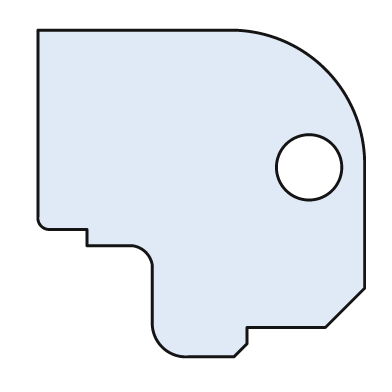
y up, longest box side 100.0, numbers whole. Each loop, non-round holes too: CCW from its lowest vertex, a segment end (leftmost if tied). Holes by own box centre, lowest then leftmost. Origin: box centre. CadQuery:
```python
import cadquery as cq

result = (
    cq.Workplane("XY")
    .moveTo(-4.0, -50.0)
    .lineTo(10.0, -50.0)
    .lineTo(14.0, -46.0)
    .lineTo(14.0, -41.0)
    .lineTo(38.0, -41.0)
    .lineTo(50.0, -29.0)
    .lineTo(50.0, 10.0)
    .threePointArc((38.0, 38.0), (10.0, 50.0))
    .lineTo(-50.0, 50.0)
    .lineTo(-50.0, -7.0)
    .threePointArc((-49.0, -10.0), (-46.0, -11.0))
    .lineTo(-35.0, -11.0)
    .lineTo(-35.0, -16.0)
    .lineTo(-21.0, -16.0)
    .threePointArc((-17.0, -18.0), (-15.0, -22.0))
    .lineTo(-15.0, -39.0)
    .threePointArc((-12.0, -47.0), (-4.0, -50.0))
    .close()
    .moveTo(33.0, 8.0)
    .circle(10.0)
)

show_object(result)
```